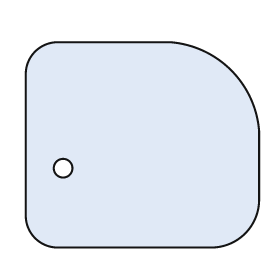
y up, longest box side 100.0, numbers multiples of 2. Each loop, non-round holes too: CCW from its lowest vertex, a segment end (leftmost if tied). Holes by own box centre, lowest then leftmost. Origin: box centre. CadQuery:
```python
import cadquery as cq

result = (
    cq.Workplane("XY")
    .moveTo(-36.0, -44.0)
    .lineTo(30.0, -44.0)
    .threePointArc((44.0, -38.0), (50.0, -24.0))
    .lineTo(50.0, 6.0)
    .threePointArc((38.0, 32.0), (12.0, 44.0))
    .lineTo(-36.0, 44.0)
    .threePointArc((-46.0, 40.0), (-50.0, 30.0))
    .lineTo(-50.0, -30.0)
    .threePointArc((-46.0, -40.0), (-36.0, -44.0))
    .close()
    .moveTo(-34.0, -10.0)
    .circle(4.0)
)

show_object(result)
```